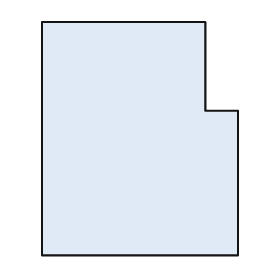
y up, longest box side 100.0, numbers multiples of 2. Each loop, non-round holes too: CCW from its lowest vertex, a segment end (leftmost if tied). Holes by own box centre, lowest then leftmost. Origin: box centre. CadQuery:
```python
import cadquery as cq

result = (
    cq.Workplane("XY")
    .moveTo(-42.0, -50.0)
    .lineTo(42.0, -50.0)
    .lineTo(42.0, 12.0)
    .lineTo(28.0, 12.0)
    .lineTo(28.0, 50.0)
    .lineTo(-42.0, 50.0)
    .close()
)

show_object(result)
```